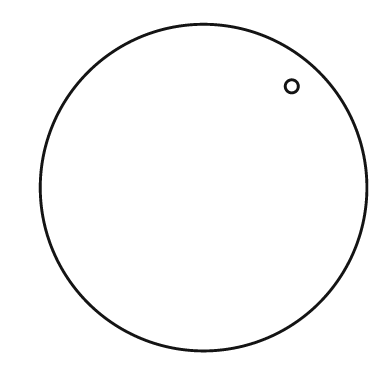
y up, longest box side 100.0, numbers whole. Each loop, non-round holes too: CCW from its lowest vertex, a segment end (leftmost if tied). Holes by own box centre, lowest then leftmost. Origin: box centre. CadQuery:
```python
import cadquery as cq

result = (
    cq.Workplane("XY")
    .moveTo(0.0, 0.0)
    .circle(50.0)
    .moveTo(27.0, 31.0)
    .circle(2.0)
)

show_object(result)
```